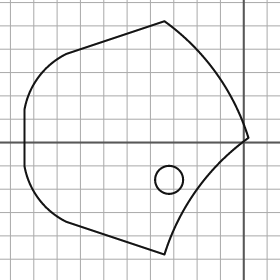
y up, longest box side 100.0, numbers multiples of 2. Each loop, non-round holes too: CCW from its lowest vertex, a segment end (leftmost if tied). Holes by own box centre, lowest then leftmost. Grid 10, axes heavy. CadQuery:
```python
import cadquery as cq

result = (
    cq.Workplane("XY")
    .moveTo(-34.0, -48.0)
    .threePointArc((-20.0, -20.0), (2.0, 2.0))
    .threePointArc((-12.0, 30.0), (-34.0, 52.0))
    .lineTo(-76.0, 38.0)
    .threePointArc((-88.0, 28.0), (-94.0, 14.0))
    .lineTo(-94.0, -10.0)
    .threePointArc((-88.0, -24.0), (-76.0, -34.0))
    .close()
    .moveTo(-32.0, -16.0)
    .circle(6.0)
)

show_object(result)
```